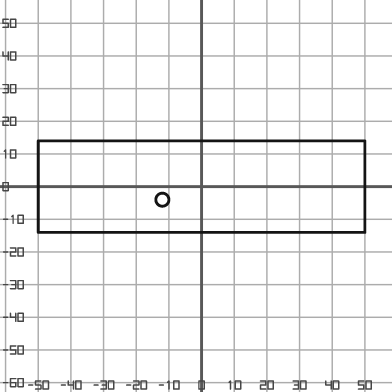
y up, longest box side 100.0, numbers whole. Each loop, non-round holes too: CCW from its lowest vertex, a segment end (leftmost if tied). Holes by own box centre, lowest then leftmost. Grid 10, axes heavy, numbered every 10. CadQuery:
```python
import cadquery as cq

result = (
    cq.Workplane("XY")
    .moveTo(-50.0, -14.0)
    .lineTo(50.0, -14.0)
    .lineTo(50.0, 14.0)
    .lineTo(-50.0, 14.0)
    .close()
    .moveTo(-12.0, -4.0)
    .circle(2.0)
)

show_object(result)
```